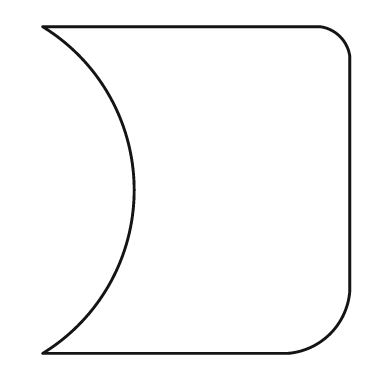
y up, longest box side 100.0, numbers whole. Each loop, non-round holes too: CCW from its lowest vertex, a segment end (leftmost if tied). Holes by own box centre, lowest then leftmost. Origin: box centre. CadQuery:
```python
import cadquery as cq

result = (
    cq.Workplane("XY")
    .moveTo(-47.0, -50.0)
    .lineTo(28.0, -50.0)
    .threePointArc((41.0, -44.0), (47.0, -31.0))
    .lineTo(47.0, 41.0)
    .threePointArc((44.0, 47.0), (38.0, 50.0))
    .lineTo(-47.0, 50.0)
    .threePointArc((-19.0, 0.0), (-47.0, -50.0))
    .close()
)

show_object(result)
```